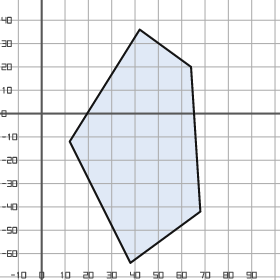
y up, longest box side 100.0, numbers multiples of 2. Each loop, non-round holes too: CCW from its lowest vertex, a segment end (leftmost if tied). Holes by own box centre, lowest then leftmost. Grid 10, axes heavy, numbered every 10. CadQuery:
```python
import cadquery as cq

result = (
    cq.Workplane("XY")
    .moveTo(38.0, -64.0)
    .lineTo(68.0, -42.0)
    .lineTo(64.0, 20.0)
    .lineTo(42.0, 36.0)
    .lineTo(12.0, -12.0)
    .close()
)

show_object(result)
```